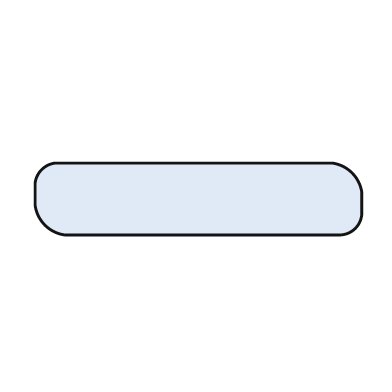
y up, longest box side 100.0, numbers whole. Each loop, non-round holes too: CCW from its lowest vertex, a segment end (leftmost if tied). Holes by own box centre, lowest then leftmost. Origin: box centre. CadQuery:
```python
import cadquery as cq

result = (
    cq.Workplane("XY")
    .moveTo(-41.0, -11.0)
    .lineTo(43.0, -11.0)
    .threePointArc((48.0, -9.0), (50.0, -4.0))
    .lineTo(50.0, 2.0)
    .threePointArc((47.0, 8.0), (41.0, 11.0))
    .lineTo(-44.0, 11.0)
    .threePointArc((-48.0, 9.0), (-50.0, 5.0))
    .lineTo(-50.0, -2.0)
    .threePointArc((-47.0, -8.0), (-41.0, -11.0))
    .close()
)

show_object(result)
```